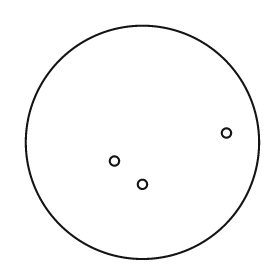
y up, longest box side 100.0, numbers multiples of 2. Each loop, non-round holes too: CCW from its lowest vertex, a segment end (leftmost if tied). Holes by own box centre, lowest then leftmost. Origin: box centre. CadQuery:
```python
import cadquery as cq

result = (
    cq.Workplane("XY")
    .moveTo(0.0, 0.0)
    .circle(50.0)
    .moveTo(0.0, -18.0)
    .circle(2.0)
    .moveTo(-12.0, -8.0)
    .circle(2.0)
    .moveTo(36.0, 4.0)
    .circle(2.0)
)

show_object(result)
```